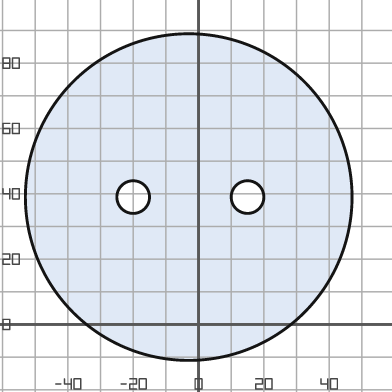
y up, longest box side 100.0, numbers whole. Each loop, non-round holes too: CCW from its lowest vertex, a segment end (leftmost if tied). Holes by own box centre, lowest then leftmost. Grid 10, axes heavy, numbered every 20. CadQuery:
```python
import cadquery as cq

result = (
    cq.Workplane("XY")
    .moveTo(-3.0, 39.0)
    .circle(50.0)
    .moveTo(-20.0, 39.0)
    .circle(5.0)
    .moveTo(15.0, 39.0)
    .circle(5.0)
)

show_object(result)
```